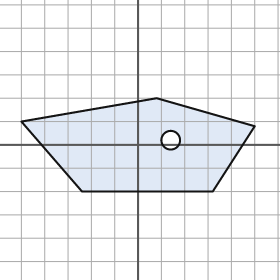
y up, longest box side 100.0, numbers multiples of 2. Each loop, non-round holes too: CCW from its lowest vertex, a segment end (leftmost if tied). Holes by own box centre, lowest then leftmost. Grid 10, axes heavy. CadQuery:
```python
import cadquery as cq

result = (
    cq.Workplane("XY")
    .moveTo(-24.0, -20.0)
    .lineTo(32.0, -20.0)
    .lineTo(50.0, 8.0)
    .lineTo(8.0, 20.0)
    .lineTo(-50.0, 10.0)
    .close()
    .moveTo(14.0, 2.0)
    .circle(4.0)
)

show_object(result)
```